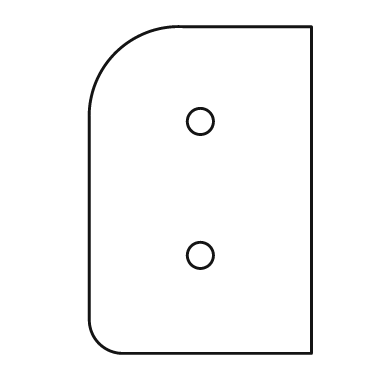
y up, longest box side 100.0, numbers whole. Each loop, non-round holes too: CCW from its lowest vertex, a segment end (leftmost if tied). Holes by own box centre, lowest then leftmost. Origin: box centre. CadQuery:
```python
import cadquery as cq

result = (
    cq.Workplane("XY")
    .moveTo(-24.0, -50.0)
    .lineTo(34.0, -50.0)
    .lineTo(34.0, 50.0)
    .lineTo(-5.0, 50.0)
    .threePointArc((-26.0, 42.0), (-34.0, 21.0))
    .lineTo(-34.0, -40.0)
    .threePointArc((-31.0, -47.0), (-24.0, -50.0))
    .close()
    .moveTo(0.0, -20.0)
    .circle(4.0)
    .moveTo(0.0, 21.0)
    .circle(4.0)
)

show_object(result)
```